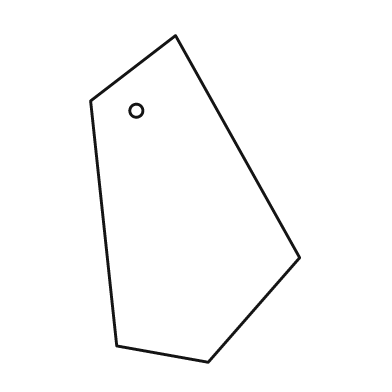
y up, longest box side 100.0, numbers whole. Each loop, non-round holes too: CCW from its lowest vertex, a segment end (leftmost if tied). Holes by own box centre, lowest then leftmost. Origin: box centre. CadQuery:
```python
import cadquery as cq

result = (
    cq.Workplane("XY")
    .moveTo(4.0, -50.0)
    .lineTo(32.0, -18.0)
    .lineTo(-6.0, 50.0)
    .lineTo(-32.0, 30.0)
    .lineTo(-24.0, -45.0)
    .close()
    .moveTo(-18.0, 27.0)
    .circle(2.0)
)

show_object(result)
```